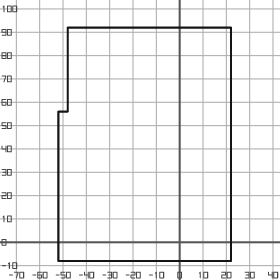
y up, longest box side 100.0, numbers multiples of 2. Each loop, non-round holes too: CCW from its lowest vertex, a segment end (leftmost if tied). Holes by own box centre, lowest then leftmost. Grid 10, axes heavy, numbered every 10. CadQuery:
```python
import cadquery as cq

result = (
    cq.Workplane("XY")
    .moveTo(-52.0, -8.0)
    .lineTo(22.0, -8.0)
    .lineTo(22.0, 92.0)
    .lineTo(-48.0, 92.0)
    .lineTo(-48.0, 56.0)
    .lineTo(-52.0, 56.0)
    .close()
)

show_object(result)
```